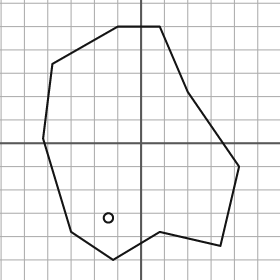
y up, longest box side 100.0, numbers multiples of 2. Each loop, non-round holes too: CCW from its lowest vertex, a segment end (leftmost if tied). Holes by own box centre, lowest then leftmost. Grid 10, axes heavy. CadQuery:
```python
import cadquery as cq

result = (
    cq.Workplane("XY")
    .moveTo(-12.0, -50.0)
    .lineTo(8.0, -38.0)
    .lineTo(34.0, -44.0)
    .lineTo(42.0, -10.0)
    .lineTo(20.0, 22.0)
    .lineTo(8.0, 50.0)
    .lineTo(-10.0, 50.0)
    .lineTo(-38.0, 34.0)
    .lineTo(-42.0, 2.0)
    .lineTo(-30.0, -38.0)
    .close()
    .moveTo(-14.0, -32.0)
    .circle(2.0)
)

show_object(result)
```